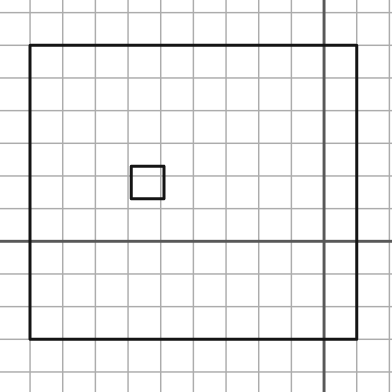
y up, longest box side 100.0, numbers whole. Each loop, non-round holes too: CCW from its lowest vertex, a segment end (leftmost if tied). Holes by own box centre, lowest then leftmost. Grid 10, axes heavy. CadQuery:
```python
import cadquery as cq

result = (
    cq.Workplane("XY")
    .moveTo(-90.0, -30.0)
    .lineTo(10.0, -30.0)
    .lineTo(10.0, 60.0)
    .lineTo(-90.0, 60.0)
    .close()
    .moveTo(-59.0, 13.0)
    .lineTo(-49.0, 13.0)
    .lineTo(-49.0, 23.0)
    .lineTo(-59.0, 23.0)
    .close()
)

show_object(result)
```